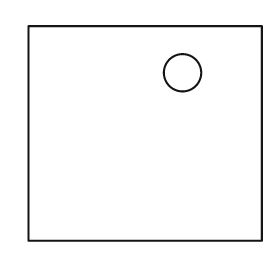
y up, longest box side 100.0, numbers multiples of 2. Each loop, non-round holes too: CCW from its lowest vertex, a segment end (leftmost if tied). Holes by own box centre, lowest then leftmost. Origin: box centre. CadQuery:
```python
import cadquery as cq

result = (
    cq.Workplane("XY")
    .moveTo(-50.0, -46.0)
    .lineTo(50.0, -46.0)
    .lineTo(50.0, 46.0)
    .lineTo(-50.0, 46.0)
    .close()
    .moveTo(16.0, 26.0)
    .circle(8.0)
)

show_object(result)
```